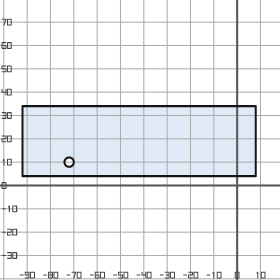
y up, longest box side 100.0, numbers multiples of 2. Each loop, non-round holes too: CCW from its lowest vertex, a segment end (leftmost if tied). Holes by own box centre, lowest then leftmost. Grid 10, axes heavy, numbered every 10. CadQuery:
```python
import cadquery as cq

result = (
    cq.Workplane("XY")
    .moveTo(-92.0, 4.0)
    .lineTo(8.0, 4.0)
    .lineTo(8.0, 34.0)
    .lineTo(-92.0, 34.0)
    .close()
    .moveTo(-72.0, 10.0)
    .circle(2.0)
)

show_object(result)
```